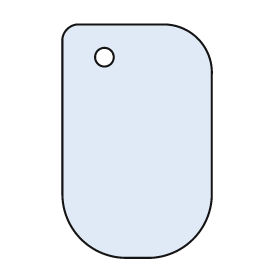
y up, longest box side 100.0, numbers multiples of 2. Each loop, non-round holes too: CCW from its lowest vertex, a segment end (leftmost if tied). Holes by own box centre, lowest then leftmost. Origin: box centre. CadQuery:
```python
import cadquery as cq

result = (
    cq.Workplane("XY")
    .moveTo(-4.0, -50.0)
    .lineTo(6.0, -50.0)
    .threePointArc((24.0, -42.0), (32.0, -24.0))
    .lineTo(32.0, 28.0)
    .threePointArc((26.0, 44.0), (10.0, 50.0))
    .lineTo(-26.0, 50.0)
    .threePointArc((-30.0, 48.0), (-32.0, 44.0))
    .lineTo(-32.0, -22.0)
    .threePointArc((-24.0, -42.0), (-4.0, -50.0))
    .close()
    .moveTo(-14.0, 36.0)
    .circle(4.0)
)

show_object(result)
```